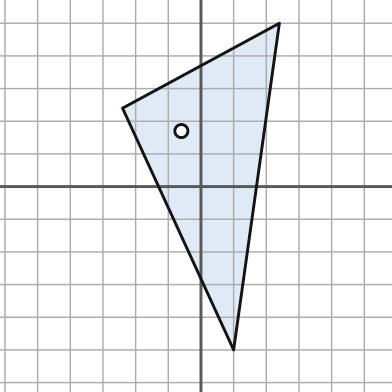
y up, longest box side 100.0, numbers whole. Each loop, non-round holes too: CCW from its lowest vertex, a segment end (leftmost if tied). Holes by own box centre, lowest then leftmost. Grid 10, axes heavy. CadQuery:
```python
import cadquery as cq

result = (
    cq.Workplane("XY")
    .moveTo(10.0, -50.0)
    .lineTo(24.0, 50.0)
    .lineTo(-24.0, 24.0)
    .close()
    .moveTo(-6.0, 17.0)
    .circle(2.0)
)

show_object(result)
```